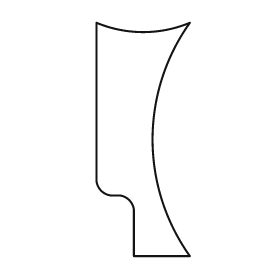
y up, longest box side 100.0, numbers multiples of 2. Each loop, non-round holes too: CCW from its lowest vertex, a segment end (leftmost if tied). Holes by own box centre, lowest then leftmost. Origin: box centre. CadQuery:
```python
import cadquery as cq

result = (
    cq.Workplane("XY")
    .moveTo(-4.0, -50.0)
    .lineTo(20.0, -50.0)
    .threePointArc((4.0, 0.0), (20.0, 50.0))
    .threePointArc((0.0, 46.0), (-20.0, 50.0))
    .lineTo(-20.0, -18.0)
    .threePointArc((-18.0, -22.0), (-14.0, -24.0))
    .lineTo(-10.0, -24.0)
    .threePointArc((-6.0, -26.0), (-4.0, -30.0))
    .close()
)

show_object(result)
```